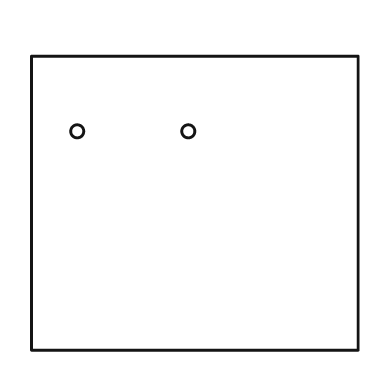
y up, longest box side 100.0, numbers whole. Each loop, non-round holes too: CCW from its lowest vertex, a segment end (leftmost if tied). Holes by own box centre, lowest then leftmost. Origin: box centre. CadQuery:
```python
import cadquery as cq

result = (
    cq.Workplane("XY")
    .moveTo(-50.0, -45.0)
    .lineTo(50.0, -45.0)
    .lineTo(50.0, 45.0)
    .lineTo(-50.0, 45.0)
    .close()
    .moveTo(-36.0, 22.0)
    .circle(2.0)
    .moveTo(-2.0, 22.0)
    .circle(2.0)
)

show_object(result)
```